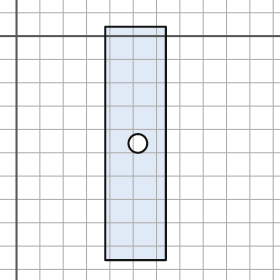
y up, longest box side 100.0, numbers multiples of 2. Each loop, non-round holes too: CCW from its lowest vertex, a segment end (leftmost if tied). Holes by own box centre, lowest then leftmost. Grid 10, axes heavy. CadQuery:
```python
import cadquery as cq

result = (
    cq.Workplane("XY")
    .moveTo(38.0, -96.0)
    .lineTo(64.0, -96.0)
    .lineTo(64.0, 4.0)
    .lineTo(38.0, 4.0)
    .close()
    .moveTo(52.0, -46.0)
    .circle(4.0)
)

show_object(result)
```